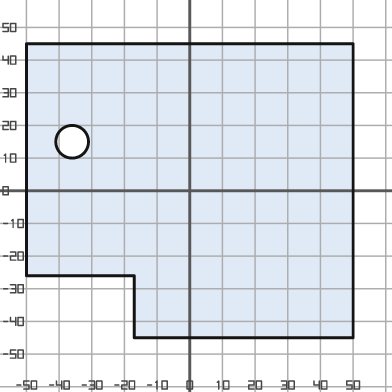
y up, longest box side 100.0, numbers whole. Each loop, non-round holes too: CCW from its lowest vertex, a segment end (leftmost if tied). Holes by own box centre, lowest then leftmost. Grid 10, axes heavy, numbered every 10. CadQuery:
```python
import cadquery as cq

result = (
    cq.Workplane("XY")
    .moveTo(-17.0, -45.0)
    .lineTo(50.0, -45.0)
    .lineTo(50.0, 45.0)
    .lineTo(-50.0, 45.0)
    .lineTo(-50.0, -26.0)
    .lineTo(-17.0, -26.0)
    .close()
    .moveTo(-36.0, 15.0)
    .circle(5.0)
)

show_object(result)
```